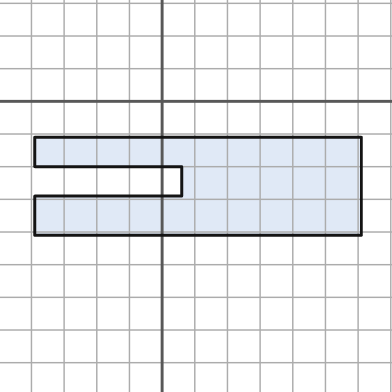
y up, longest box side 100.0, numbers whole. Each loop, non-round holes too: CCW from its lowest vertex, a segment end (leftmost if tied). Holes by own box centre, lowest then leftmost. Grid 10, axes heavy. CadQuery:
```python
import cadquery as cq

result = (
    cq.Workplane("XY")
    .moveTo(-39.0, -41.0)
    .lineTo(61.0, -41.0)
    .lineTo(61.0, -11.0)
    .lineTo(-39.0, -11.0)
    .lineTo(-39.0, -20.0)
    .lineTo(6.0, -20.0)
    .lineTo(6.0, -29.0)
    .lineTo(-39.0, -29.0)
    .close()
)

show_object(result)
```